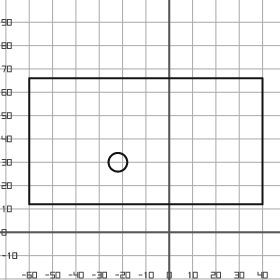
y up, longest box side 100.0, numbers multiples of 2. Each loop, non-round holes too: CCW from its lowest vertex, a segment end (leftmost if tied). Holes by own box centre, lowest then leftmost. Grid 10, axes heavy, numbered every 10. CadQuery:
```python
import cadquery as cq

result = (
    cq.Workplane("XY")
    .moveTo(-60.0, 12.0)
    .lineTo(40.0, 12.0)
    .lineTo(40.0, 66.0)
    .lineTo(-60.0, 66.0)
    .close()
    .moveTo(-22.0, 30.0)
    .circle(4.0)
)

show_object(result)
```